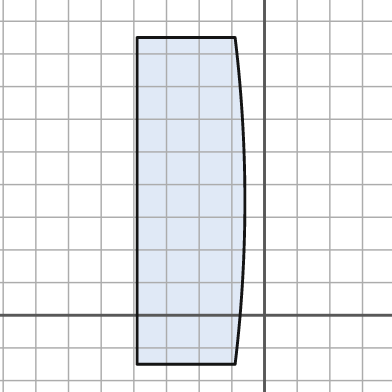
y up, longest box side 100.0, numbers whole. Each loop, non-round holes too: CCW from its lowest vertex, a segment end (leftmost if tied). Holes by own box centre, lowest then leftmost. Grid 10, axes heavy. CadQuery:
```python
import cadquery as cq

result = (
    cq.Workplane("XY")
    .moveTo(-39.0, -15.0)
    .lineTo(-9.0, -15.0)
    .threePointArc((-6.0, 35.0), (-9.0, 85.0))
    .lineTo(-39.0, 85.0)
    .close()
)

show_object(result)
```